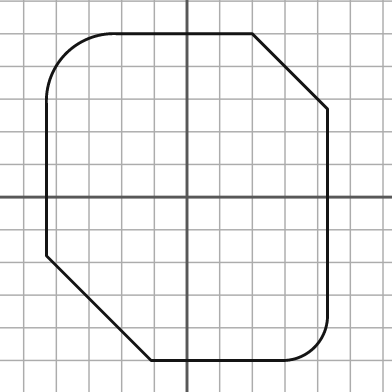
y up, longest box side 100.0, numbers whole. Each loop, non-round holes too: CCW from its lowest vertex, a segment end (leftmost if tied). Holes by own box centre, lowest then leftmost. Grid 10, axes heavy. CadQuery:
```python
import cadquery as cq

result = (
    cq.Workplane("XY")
    .moveTo(-11.0, -50.0)
    .lineTo(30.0, -50.0)
    .threePointArc((39.0, -46.0), (43.0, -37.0))
    .lineTo(43.0, 27.0)
    .lineTo(20.0, 50.0)
    .lineTo(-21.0, 50.0)
    .threePointArc((-37.0, 44.0), (-43.0, 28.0))
    .lineTo(-43.0, -18.0)
    .close()
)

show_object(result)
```